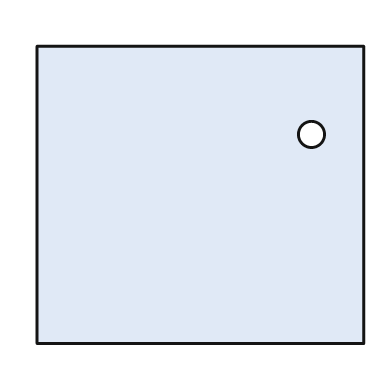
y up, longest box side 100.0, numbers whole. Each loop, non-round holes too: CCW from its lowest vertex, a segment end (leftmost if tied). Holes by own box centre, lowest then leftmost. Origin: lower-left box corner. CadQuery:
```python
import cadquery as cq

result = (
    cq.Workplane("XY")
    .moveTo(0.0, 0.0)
    .lineTo(100.0, 0.0)
    .lineTo(100.0, 91.0)
    .lineTo(0.0, 91.0)
    .close()
    .moveTo(84.0, 64.0)
    .circle(4.0)
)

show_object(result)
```